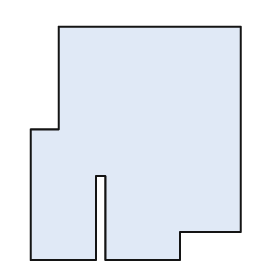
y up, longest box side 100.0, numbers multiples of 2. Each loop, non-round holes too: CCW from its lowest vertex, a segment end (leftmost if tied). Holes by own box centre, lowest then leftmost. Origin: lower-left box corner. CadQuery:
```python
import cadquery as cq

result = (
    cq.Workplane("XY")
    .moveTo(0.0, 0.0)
    .lineTo(28.0, 0.0)
    .lineTo(28.0, 36.0)
    .lineTo(32.0, 36.0)
    .lineTo(32.0, 0.0)
    .lineTo(64.0, 0.0)
    .lineTo(64.0, 12.0)
    .lineTo(90.0, 12.0)
    .lineTo(90.0, 100.0)
    .lineTo(12.0, 100.0)
    .lineTo(12.0, 56.0)
    .lineTo(0.0, 56.0)
    .close()
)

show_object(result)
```